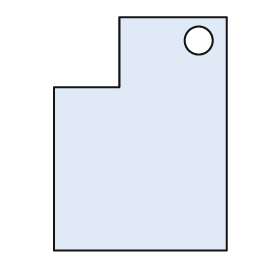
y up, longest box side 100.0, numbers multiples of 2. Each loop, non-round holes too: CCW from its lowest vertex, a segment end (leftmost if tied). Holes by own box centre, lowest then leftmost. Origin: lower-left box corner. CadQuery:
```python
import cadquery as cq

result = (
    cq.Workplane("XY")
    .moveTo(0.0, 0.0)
    .lineTo(74.0, 0.0)
    .lineTo(74.0, 100.0)
    .lineTo(28.0, 100.0)
    .lineTo(28.0, 70.0)
    .lineTo(0.0, 70.0)
    .close()
    .moveTo(62.0, 90.0)
    .circle(6.0)
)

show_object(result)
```